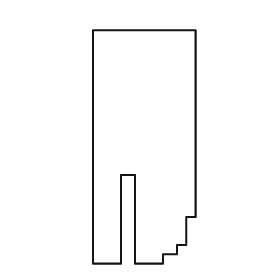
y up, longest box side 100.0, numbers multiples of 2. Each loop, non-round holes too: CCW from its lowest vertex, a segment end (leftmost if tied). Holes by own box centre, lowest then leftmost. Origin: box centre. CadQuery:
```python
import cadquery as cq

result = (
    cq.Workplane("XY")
    .moveTo(-22.0, -50.0)
    .lineTo(-10.0, -50.0)
    .lineTo(-10.0, -12.0)
    .lineTo(-4.0, -12.0)
    .lineTo(-4.0, -50.0)
    .lineTo(8.0, -50.0)
    .lineTo(8.0, -46.0)
    .lineTo(14.0, -46.0)
    .lineTo(14.0, -42.0)
    .lineTo(18.0, -42.0)
    .lineTo(18.0, -30.0)
    .lineTo(22.0, -30.0)
    .lineTo(22.0, 50.0)
    .lineTo(-22.0, 50.0)
    .close()
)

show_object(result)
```